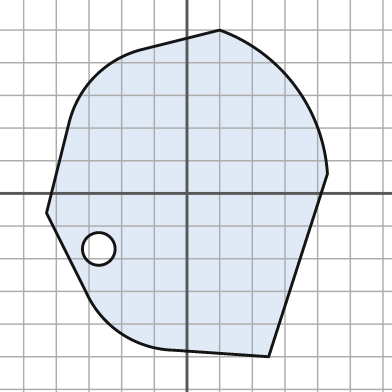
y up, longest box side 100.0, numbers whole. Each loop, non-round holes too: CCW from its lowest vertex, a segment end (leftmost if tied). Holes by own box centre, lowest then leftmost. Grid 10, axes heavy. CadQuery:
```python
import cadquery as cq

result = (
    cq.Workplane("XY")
    .moveTo(25.0, -50.0)
    .lineTo(43.0, 6.0)
    .threePointArc((33.0, 33.0), (10.0, 50.0))
    .lineTo(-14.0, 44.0)
    .threePointArc((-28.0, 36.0), (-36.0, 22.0))
    .lineTo(-43.0, -6.0)
    .lineTo(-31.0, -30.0)
    .threePointArc((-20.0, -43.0), (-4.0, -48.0))
    .close()
    .moveTo(-27.0, -17.0)
    .circle(5.0)
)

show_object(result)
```